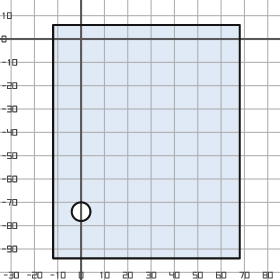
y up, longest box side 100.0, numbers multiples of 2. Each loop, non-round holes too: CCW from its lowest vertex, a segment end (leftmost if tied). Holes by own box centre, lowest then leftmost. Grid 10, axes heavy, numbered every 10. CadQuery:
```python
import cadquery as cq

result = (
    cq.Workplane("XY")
    .moveTo(-12.0, -94.0)
    .lineTo(68.0, -94.0)
    .lineTo(68.0, 6.0)
    .lineTo(-12.0, 6.0)
    .close()
    .moveTo(0.0, -74.0)
    .circle(4.0)
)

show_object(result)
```